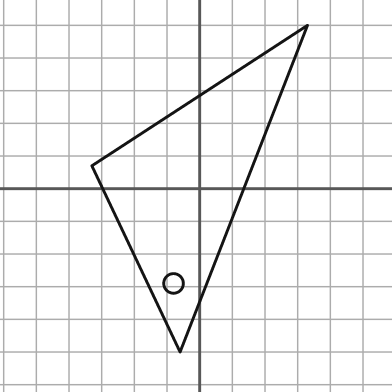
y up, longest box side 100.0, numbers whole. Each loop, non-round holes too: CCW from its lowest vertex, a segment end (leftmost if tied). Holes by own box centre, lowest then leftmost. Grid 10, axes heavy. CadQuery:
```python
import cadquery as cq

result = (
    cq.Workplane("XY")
    .moveTo(-6.0, -50.0)
    .lineTo(33.0, 50.0)
    .lineTo(-33.0, 7.0)
    .close()
    .moveTo(-8.0, -29.0)
    .circle(3.0)
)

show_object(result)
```